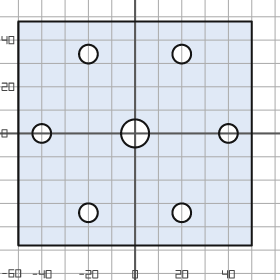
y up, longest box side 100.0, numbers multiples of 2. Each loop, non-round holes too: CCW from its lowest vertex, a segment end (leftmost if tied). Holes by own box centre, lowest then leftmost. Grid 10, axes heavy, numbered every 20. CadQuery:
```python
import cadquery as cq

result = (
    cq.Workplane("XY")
    .moveTo(-50.0, -48.0)
    .lineTo(50.0, -48.0)
    .lineTo(50.0, 48.0)
    .lineTo(-50.0, 48.0)
    .close()
    .moveTo(-20.0, -34.0)
    .circle(4.0)
    .moveTo(20.0, -34.0)
    .circle(4.0)
    .moveTo(-40.0, 0.0)
    .circle(4.0)
    .moveTo(0.0, 0.0)
    .circle(6.0)
    .moveTo(40.0, 0.0)
    .circle(4.0)
    .moveTo(-20.0, 34.0)
    .circle(4.0)
    .moveTo(20.0, 34.0)
    .circle(4.0)
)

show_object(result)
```